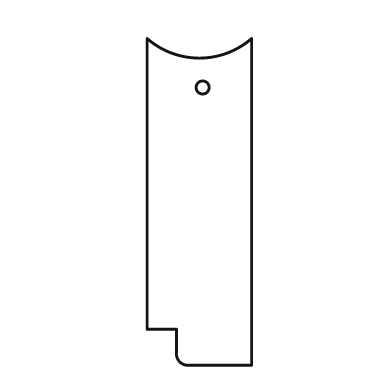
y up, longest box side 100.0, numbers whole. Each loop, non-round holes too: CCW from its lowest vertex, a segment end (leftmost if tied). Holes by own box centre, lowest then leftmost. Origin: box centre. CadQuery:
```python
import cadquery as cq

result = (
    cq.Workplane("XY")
    .moveTo(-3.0, -50.0)
    .lineTo(16.0, -50.0)
    .lineTo(16.0, 50.0)
    .threePointArc((0.0, 44.0), (-16.0, 50.0))
    .lineTo(-16.0, -39.0)
    .lineTo(-7.0, -39.0)
    .lineTo(-7.0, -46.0)
    .threePointArc((-6.0, -49.0), (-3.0, -50.0))
    .close()
    .moveTo(1.0, 35.0)
    .circle(2.0)
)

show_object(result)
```